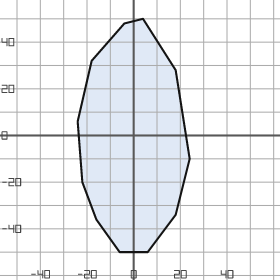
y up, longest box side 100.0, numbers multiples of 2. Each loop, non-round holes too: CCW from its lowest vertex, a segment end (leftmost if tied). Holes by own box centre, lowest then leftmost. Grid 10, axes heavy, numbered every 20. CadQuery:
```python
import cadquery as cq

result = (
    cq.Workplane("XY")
    .moveTo(-6.0, -50.0)
    .lineTo(6.0, -50.0)
    .lineTo(18.0, -34.0)
    .lineTo(24.0, -10.0)
    .lineTo(18.0, 28.0)
    .lineTo(4.0, 50.0)
    .lineTo(-4.0, 48.0)
    .lineTo(-18.0, 32.0)
    .lineTo(-24.0, 6.0)
    .lineTo(-22.0, -20.0)
    .lineTo(-16.0, -36.0)
    .close()
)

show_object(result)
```